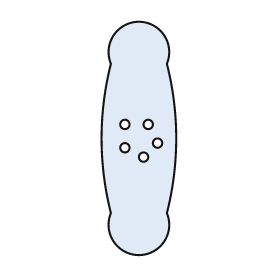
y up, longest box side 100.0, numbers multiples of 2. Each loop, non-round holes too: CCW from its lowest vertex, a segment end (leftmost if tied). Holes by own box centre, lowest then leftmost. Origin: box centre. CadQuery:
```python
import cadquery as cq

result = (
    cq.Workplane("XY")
    .moveTo(-12.0, -32.0)
    .threePointArc((0.0, -50.0), (12.0, -32.0))
    .threePointArc((16.0, 0.0), (12.0, 32.0))
    .threePointArc((0.0, 50.0), (-12.0, 32.0))
    .threePointArc((-16.0, 0.0), (-12.0, -32.0))
    .close()
    .moveTo(2.0, -8.0)
    .circle(2.0)
    .moveTo(-6.0, -4.0)
    .circle(2.0)
    .moveTo(8.0, -2.0)
    .circle(2.0)
    .moveTo(-6.0, 6.0)
    .circle(2.0)
    .moveTo(4.0, 6.0)
    .circle(2.0)
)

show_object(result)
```